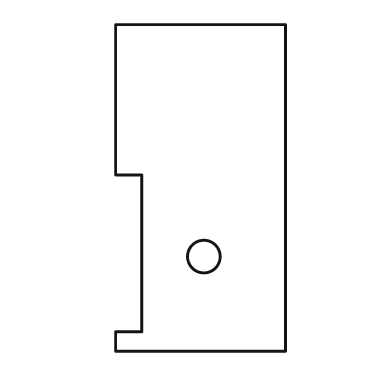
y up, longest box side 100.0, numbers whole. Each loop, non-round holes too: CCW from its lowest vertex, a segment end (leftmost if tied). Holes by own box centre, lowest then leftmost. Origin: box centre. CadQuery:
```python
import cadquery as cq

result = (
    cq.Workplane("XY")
    .moveTo(-26.0, -50.0)
    .lineTo(26.0, -50.0)
    .lineTo(26.0, 50.0)
    .lineTo(-26.0, 50.0)
    .lineTo(-26.0, 4.0)
    .lineTo(-18.0, 4.0)
    .lineTo(-18.0, -44.0)
    .lineTo(-26.0, -44.0)
    .close()
    .moveTo(1.0, -21.0)
    .circle(5.0)
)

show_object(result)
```